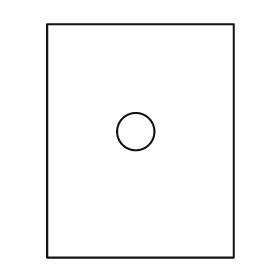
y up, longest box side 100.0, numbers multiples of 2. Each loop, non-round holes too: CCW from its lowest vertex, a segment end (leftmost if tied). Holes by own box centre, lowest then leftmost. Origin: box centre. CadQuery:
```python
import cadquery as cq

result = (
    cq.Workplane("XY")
    .moveTo(-40.0, -50.0)
    .lineTo(40.0, -50.0)
    .lineTo(40.0, 50.0)
    .lineTo(-40.0, 50.0)
    .close()
    .moveTo(-2.0, 4.0)
    .circle(8.0)
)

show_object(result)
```